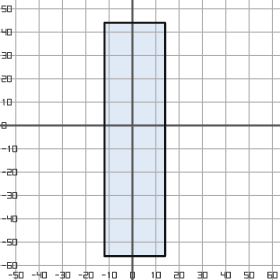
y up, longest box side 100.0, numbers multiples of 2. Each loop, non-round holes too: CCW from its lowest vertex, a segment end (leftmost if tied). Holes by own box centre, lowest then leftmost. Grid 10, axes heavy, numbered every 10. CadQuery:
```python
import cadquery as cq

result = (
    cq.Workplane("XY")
    .moveTo(-12.0, -56.0)
    .lineTo(14.0, -56.0)
    .lineTo(14.0, 44.0)
    .lineTo(-12.0, 44.0)
    .close()
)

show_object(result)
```